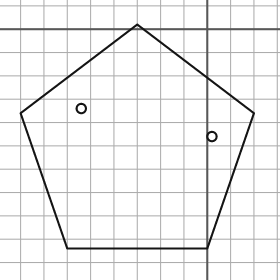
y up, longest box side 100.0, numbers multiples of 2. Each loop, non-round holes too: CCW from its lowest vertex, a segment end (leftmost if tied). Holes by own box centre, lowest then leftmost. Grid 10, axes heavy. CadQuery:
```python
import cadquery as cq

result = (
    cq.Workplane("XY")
    .moveTo(-60.0, -94.0)
    .lineTo(0.0, -94.0)
    .lineTo(20.0, -36.0)
    .lineTo(-30.0, 2.0)
    .lineTo(-80.0, -36.0)
    .close()
    .moveTo(2.0, -46.0)
    .circle(2.0)
    .moveTo(-54.0, -34.0)
    .circle(2.0)
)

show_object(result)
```